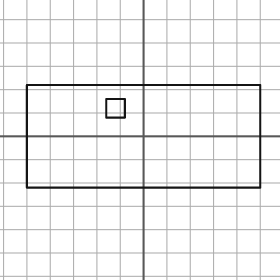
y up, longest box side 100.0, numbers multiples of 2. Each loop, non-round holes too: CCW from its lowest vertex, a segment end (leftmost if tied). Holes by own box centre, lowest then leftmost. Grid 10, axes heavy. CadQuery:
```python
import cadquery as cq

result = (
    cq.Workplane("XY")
    .moveTo(-50.0, -22.0)
    .lineTo(50.0, -22.0)
    .lineTo(50.0, 22.0)
    .lineTo(-50.0, 22.0)
    .close()
    .moveTo(-16.0, 8.0)
    .lineTo(-8.0, 8.0)
    .lineTo(-8.0, 16.0)
    .lineTo(-16.0, 16.0)
    .close()
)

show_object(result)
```